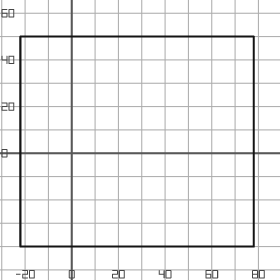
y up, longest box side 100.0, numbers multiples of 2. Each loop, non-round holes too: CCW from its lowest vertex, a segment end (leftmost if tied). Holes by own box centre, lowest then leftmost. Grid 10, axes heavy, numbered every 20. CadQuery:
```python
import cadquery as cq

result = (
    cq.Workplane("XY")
    .moveTo(-22.0, -40.0)
    .lineTo(78.0, -40.0)
    .lineTo(78.0, 50.0)
    .lineTo(-22.0, 50.0)
    .close()
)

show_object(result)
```